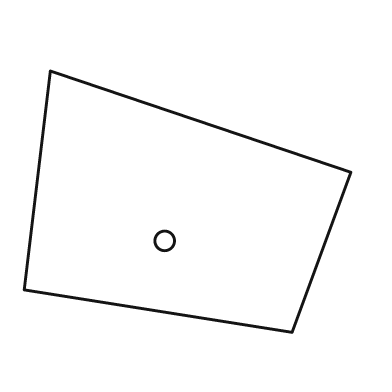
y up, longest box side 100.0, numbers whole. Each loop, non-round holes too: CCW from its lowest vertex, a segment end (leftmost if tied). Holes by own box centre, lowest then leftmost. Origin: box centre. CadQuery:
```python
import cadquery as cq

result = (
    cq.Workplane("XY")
    .moveTo(32.0, -40.0)
    .lineTo(50.0, 9.0)
    .lineTo(-42.0, 40.0)
    .lineTo(-50.0, -27.0)
    .close()
    .moveTo(-7.0, -12.0)
    .circle(3.0)
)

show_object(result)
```